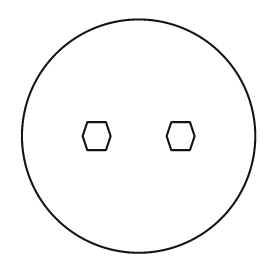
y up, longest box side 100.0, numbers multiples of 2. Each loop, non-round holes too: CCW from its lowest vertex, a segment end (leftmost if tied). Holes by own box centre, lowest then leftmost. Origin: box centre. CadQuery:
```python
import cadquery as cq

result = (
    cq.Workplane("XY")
    .moveTo(0.0, 0.0)
    .circle(50.0)
    .moveTo(-22.0, -6.0)
    .lineTo(-14.0, -6.0)
    .lineTo(-12.0, 0.0)
    .lineTo(-14.0, 6.0)
    .lineTo(-22.0, 6.0)
    .lineTo(-24.0, 0.0)
    .close()
    .moveTo(14.0, -6.0)
    .lineTo(22.0, -6.0)
    .lineTo(24.0, 0.0)
    .lineTo(22.0, 6.0)
    .lineTo(14.0, 6.0)
    .lineTo(12.0, 0.0)
    .close()
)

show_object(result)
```